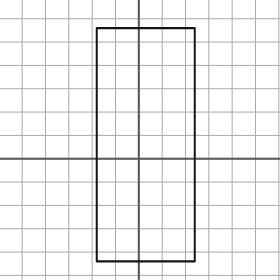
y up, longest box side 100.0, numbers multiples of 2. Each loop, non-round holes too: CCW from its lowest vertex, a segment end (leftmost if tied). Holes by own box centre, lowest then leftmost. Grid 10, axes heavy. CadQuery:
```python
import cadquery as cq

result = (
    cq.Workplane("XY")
    .moveTo(-18.0, -44.0)
    .lineTo(24.0, -44.0)
    .lineTo(24.0, 56.0)
    .lineTo(-18.0, 56.0)
    .close()
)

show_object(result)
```